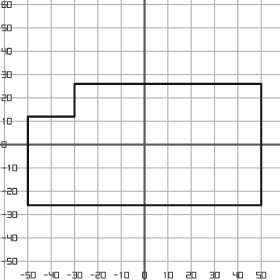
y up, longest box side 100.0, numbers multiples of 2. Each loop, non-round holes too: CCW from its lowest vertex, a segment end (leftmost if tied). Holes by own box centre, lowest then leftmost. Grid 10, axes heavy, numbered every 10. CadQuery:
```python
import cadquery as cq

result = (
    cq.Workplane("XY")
    .moveTo(-50.0, -26.0)
    .lineTo(50.0, -26.0)
    .lineTo(50.0, 26.0)
    .lineTo(-30.0, 26.0)
    .lineTo(-30.0, 12.0)
    .lineTo(-50.0, 12.0)
    .close()
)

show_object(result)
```